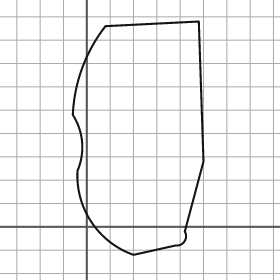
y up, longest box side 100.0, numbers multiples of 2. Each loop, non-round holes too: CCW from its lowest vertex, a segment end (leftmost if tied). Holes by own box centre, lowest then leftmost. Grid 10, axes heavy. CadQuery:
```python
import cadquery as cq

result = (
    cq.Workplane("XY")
    .moveTo(20.0, -12.0)
    .lineTo(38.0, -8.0)
    .threePointArc((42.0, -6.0), (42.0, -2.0))
    .lineTo(50.0, 28.0)
    .lineTo(48.0, 88.0)
    .lineTo(8.0, 86.0)
    .threePointArc((-2.0, 68.0), (-6.0, 48.0))
    .threePointArc((-2.0, 36.0), (-4.0, 24.0))
    .threePointArc((2.0, 2.0), (20.0, -12.0))
    .close()
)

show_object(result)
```